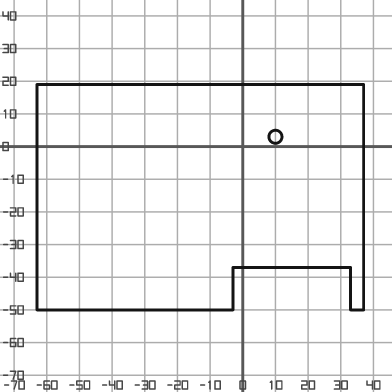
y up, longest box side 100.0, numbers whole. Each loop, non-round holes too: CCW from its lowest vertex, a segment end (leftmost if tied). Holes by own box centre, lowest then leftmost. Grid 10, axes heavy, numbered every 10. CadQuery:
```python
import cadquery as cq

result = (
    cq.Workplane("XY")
    .moveTo(-63.0, -50.0)
    .lineTo(-3.0, -50.0)
    .lineTo(-3.0, -37.0)
    .lineTo(33.0, -37.0)
    .lineTo(33.0, -50.0)
    .lineTo(37.0, -50.0)
    .lineTo(37.0, 19.0)
    .lineTo(-63.0, 19.0)
    .close()
    .moveTo(10.0, 3.0)
    .circle(2.0)
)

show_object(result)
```